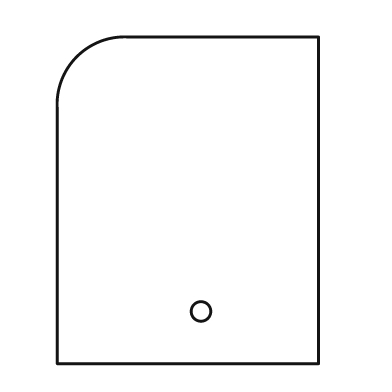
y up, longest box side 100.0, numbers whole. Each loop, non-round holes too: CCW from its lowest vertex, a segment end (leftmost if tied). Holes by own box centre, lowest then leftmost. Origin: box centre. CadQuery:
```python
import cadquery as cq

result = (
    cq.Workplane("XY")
    .moveTo(-40.0, -50.0)
    .lineTo(40.0, -50.0)
    .lineTo(40.0, 50.0)
    .lineTo(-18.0, 50.0)
    .threePointArc((-34.0, 44.0), (-40.0, 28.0))
    .close()
    .moveTo(4.0, -34.0)
    .circle(3.0)
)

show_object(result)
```